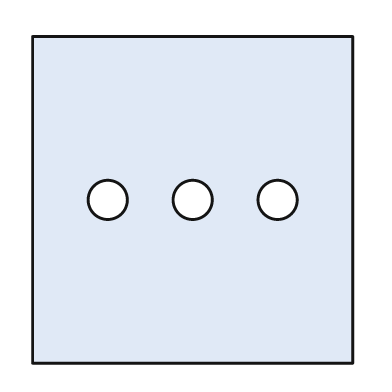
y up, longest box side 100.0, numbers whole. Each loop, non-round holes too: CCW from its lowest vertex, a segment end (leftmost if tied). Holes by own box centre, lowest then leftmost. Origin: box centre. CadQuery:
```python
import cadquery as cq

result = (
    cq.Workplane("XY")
    .moveTo(-49.0, -50.0)
    .lineTo(49.0, -50.0)
    .lineTo(49.0, 50.0)
    .lineTo(-49.0, 50.0)
    .close()
    .moveTo(-26.0, 0.0)
    .circle(6.0)
    .moveTo(0.0, 0.0)
    .circle(6.0)
    .moveTo(26.0, 0.0)
    .circle(6.0)
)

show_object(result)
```